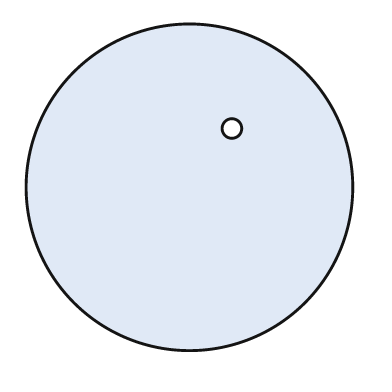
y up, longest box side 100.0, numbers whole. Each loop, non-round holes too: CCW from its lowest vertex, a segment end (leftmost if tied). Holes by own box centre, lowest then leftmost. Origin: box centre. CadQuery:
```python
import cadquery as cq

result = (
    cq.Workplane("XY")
    .moveTo(0.0, 0.0)
    .circle(50.0)
    .moveTo(13.0, 18.0)
    .circle(3.0)
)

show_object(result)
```